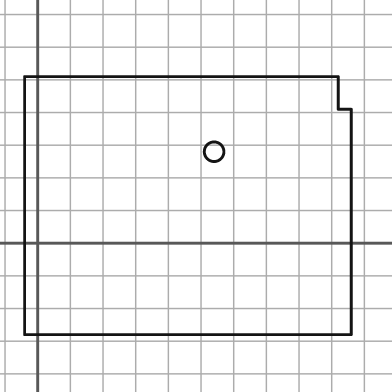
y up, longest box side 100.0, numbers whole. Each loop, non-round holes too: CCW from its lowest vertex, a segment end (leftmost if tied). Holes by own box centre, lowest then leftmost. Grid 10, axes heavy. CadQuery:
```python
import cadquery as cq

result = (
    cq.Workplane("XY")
    .moveTo(-4.0, -28.0)
    .lineTo(96.0, -28.0)
    .lineTo(96.0, 41.0)
    .lineTo(92.0, 41.0)
    .lineTo(92.0, 51.0)
    .lineTo(-4.0, 51.0)
    .close()
    .moveTo(54.0, 28.0)
    .circle(3.0)
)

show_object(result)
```